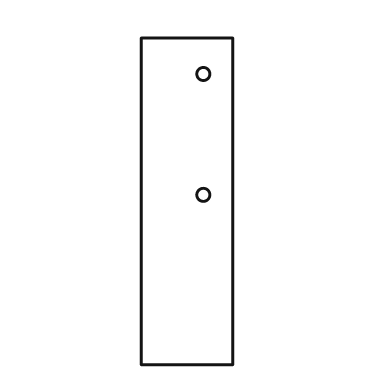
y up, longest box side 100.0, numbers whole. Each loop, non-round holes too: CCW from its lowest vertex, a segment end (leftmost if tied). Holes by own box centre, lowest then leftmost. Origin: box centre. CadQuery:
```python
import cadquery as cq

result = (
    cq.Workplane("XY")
    .moveTo(-14.0, -50.0)
    .lineTo(14.0, -50.0)
    .lineTo(14.0, 50.0)
    .lineTo(-14.0, 50.0)
    .close()
    .moveTo(5.0, 2.0)
    .circle(2.0)
    .moveTo(5.0, 39.0)
    .circle(2.0)
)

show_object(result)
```